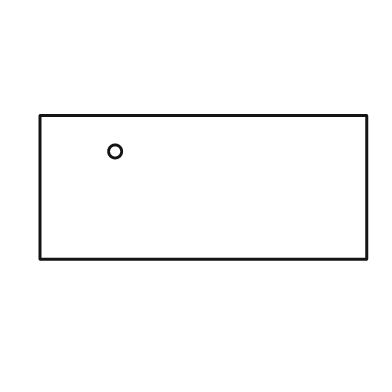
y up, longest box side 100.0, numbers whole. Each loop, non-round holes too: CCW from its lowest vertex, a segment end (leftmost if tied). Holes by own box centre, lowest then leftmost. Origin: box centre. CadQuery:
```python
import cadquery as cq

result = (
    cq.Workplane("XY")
    .moveTo(-50.0, -22.0)
    .lineTo(50.0, -22.0)
    .lineTo(50.0, 22.0)
    .lineTo(-50.0, 22.0)
    .close()
    .moveTo(-27.0, 11.0)
    .circle(2.0)
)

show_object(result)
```